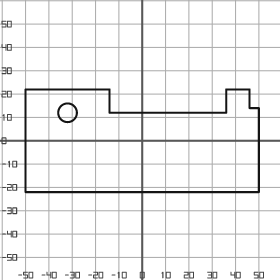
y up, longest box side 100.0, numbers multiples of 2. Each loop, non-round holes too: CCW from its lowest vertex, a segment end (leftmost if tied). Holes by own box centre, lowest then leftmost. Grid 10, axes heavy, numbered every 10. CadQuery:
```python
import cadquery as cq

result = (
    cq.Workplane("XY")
    .moveTo(-50.0, -22.0)
    .lineTo(50.0, -22.0)
    .lineTo(50.0, 14.0)
    .lineTo(46.0, 14.0)
    .lineTo(46.0, 22.0)
    .lineTo(36.0, 22.0)
    .lineTo(36.0, 12.0)
    .lineTo(-14.0, 12.0)
    .lineTo(-14.0, 22.0)
    .lineTo(-50.0, 22.0)
    .close()
    .moveTo(-32.0, 12.0)
    .circle(4.0)
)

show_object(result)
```